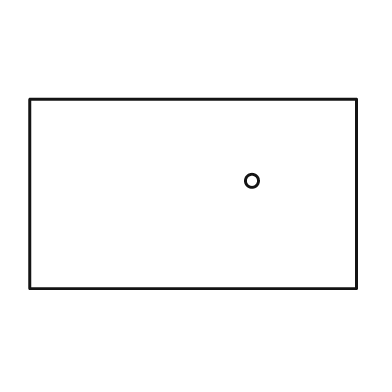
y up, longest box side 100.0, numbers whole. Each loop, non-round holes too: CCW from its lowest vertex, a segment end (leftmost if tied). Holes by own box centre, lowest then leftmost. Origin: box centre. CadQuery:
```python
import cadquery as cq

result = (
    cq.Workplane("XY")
    .moveTo(-50.0, -29.0)
    .lineTo(50.0, -29.0)
    .lineTo(50.0, 29.0)
    .lineTo(-50.0, 29.0)
    .close()
    .moveTo(18.0, 4.0)
    .circle(2.0)
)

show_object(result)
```